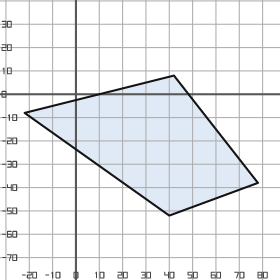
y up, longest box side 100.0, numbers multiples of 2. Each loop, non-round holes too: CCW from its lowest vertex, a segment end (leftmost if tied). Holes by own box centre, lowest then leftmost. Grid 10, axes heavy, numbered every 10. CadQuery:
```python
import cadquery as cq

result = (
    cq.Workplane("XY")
    .moveTo(40.0, -52.0)
    .lineTo(78.0, -38.0)
    .lineTo(42.0, 8.0)
    .lineTo(-22.0, -8.0)
    .close()
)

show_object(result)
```